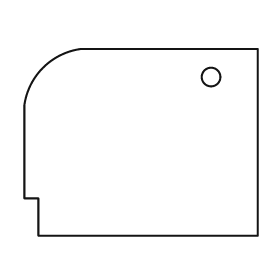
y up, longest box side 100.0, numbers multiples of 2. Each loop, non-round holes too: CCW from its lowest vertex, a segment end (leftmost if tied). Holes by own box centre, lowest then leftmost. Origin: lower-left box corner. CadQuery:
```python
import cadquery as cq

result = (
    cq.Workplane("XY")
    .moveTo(6.0, 0.0)
    .lineTo(100.0, 0.0)
    .lineTo(100.0, 80.0)
    .lineTo(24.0, 80.0)
    .threePointArc((8.0, 72.0), (0.0, 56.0))
    .lineTo(0.0, 16.0)
    .lineTo(6.0, 16.0)
    .close()
    .moveTo(80.0, 68.0)
    .circle(4.0)
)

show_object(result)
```